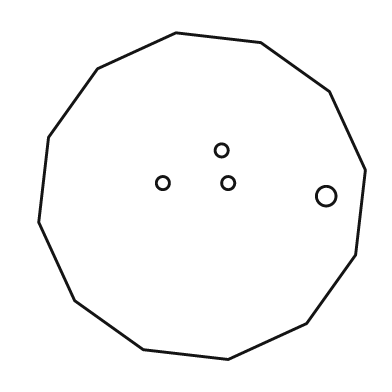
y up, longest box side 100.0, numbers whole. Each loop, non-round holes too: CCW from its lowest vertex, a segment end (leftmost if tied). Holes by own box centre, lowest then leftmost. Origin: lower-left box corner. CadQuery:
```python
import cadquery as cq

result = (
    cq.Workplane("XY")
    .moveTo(58.0, 0.0)
    .lineTo(82.0, 11.0)
    .lineTo(97.0, 32.0)
    .lineTo(100.0, 58.0)
    .lineTo(89.0, 82.0)
    .lineTo(68.0, 97.0)
    .lineTo(42.0, 100.0)
    .lineTo(18.0, 89.0)
    .lineTo(3.0, 68.0)
    .lineTo(0.0, 42.0)
    .lineTo(11.0, 18.0)
    .lineTo(32.0, 3.0)
    .close()
    .moveTo(88.0, 50.0)
    .circle(3.0)
    .moveTo(38.0, 54.0)
    .circle(2.0)
    .moveTo(58.0, 54.0)
    .circle(2.0)
    .moveTo(56.0, 64.0)
    .circle(2.0)
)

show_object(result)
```